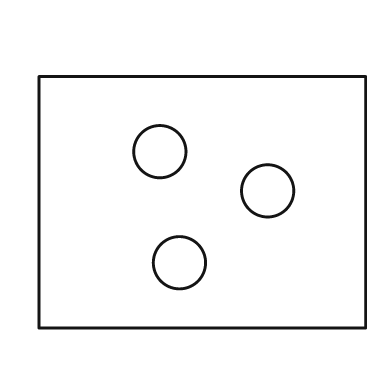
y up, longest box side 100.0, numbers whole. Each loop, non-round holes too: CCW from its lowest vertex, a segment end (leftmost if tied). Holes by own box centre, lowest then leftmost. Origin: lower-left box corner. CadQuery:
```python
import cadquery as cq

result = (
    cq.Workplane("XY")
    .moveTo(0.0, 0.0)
    .lineTo(100.0, 0.0)
    .lineTo(100.0, 77.0)
    .lineTo(0.0, 77.0)
    .close()
    .moveTo(43.0, 20.0)
    .circle(8.0)
    .moveTo(70.0, 42.0)
    .circle(8.0)
    .moveTo(37.0, 54.0)
    .circle(8.0)
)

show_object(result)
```